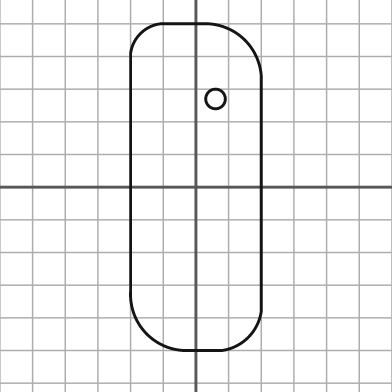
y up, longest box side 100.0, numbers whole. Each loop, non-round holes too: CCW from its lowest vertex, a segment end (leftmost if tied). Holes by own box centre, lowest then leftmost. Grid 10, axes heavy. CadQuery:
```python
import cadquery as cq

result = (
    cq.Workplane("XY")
    .moveTo(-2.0, -50.0)
    .lineTo(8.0, -50.0)
    .threePointArc((16.0, -46.0), (20.0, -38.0))
    .lineTo(20.0, 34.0)
    .threePointArc((15.0, 45.0), (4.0, 50.0))
    .lineTo(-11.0, 50.0)
    .threePointArc((-17.0, 47.0), (-20.0, 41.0))
    .lineTo(-20.0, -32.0)
    .threePointArc((-15.0, -45.0), (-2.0, -50.0))
    .close()
    .moveTo(6.0, 27.0)
    .circle(3.0)
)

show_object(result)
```